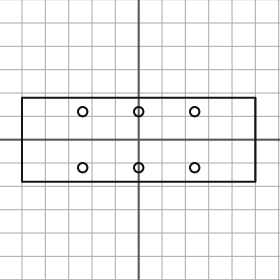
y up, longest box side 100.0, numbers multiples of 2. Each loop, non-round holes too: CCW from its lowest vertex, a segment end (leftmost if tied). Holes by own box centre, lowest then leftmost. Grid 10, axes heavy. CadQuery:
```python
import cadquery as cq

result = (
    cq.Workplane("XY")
    .moveTo(-50.0, -18.0)
    .lineTo(50.0, -18.0)
    .lineTo(50.0, 18.0)
    .lineTo(-50.0, 18.0)
    .close()
    .moveTo(-24.0, -12.0)
    .circle(2.0)
    .moveTo(0.0, -12.0)
    .circle(2.0)
    .moveTo(24.0, -12.0)
    .circle(2.0)
    .moveTo(-24.0, 12.0)
    .circle(2.0)
    .moveTo(0.0, 12.0)
    .circle(2.0)
    .moveTo(24.0, 12.0)
    .circle(2.0)
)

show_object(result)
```